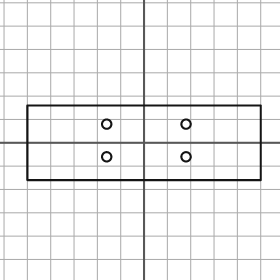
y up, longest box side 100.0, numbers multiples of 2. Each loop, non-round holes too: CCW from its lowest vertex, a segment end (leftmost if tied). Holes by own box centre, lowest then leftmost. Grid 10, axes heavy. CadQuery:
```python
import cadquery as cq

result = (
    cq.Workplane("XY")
    .moveTo(-50.0, -16.0)
    .lineTo(50.0, -16.0)
    .lineTo(50.0, 16.0)
    .lineTo(-50.0, 16.0)
    .close()
    .moveTo(-16.0, -6.0)
    .circle(2.0)
    .moveTo(18.0, -6.0)
    .circle(2.0)
    .moveTo(-16.0, 8.0)
    .circle(2.0)
    .moveTo(18.0, 8.0)
    .circle(2.0)
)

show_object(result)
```